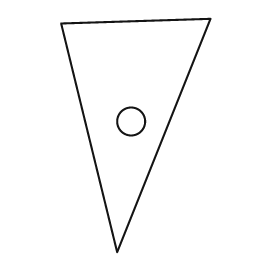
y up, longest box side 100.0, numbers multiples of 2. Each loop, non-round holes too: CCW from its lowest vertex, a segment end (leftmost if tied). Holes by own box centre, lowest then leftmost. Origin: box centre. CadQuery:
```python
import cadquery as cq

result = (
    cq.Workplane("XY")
    .moveTo(-8.0, -50.0)
    .lineTo(32.0, 50.0)
    .lineTo(-32.0, 48.0)
    .close()
    .moveTo(-2.0, 6.0)
    .circle(6.0)
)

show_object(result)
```